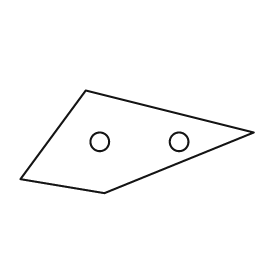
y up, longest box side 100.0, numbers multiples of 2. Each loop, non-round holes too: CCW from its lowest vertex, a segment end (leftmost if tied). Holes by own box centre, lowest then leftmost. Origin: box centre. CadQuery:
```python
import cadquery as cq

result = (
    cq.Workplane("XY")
    .moveTo(-14.0, -22.0)
    .lineTo(50.0, 4.0)
    .lineTo(-22.0, 22.0)
    .lineTo(-50.0, -16.0)
    .close()
    .moveTo(-16.0, 0.0)
    .circle(4.0)
    .moveTo(18.0, 0.0)
    .circle(4.0)
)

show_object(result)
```